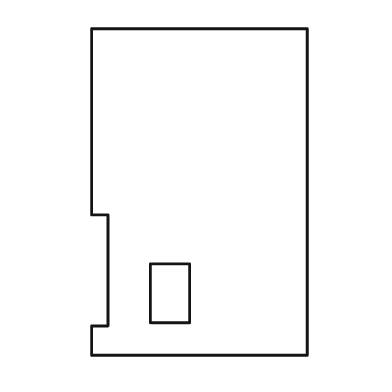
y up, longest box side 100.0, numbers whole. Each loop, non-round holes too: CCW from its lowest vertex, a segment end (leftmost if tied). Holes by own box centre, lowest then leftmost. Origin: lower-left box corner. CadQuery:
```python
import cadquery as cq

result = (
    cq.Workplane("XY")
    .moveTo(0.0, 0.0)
    .lineTo(66.0, 0.0)
    .lineTo(66.0, 100.0)
    .lineTo(0.0, 100.0)
    .lineTo(0.0, 43.0)
    .lineTo(5.0, 43.0)
    .lineTo(5.0, 9.0)
    .lineTo(0.0, 9.0)
    .close()
    .moveTo(18.0, 10.0)
    .lineTo(30.0, 10.0)
    .lineTo(30.0, 28.0)
    .lineTo(18.0, 28.0)
    .close()
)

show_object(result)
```